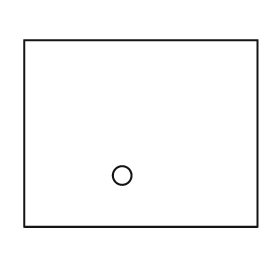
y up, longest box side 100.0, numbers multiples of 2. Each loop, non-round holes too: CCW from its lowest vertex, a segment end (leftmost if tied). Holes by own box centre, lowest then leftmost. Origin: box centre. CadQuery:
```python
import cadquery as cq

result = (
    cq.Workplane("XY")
    .moveTo(-50.0, -40.0)
    .lineTo(50.0, -40.0)
    .lineTo(50.0, 40.0)
    .lineTo(-50.0, 40.0)
    .close()
    .moveTo(-8.0, -18.0)
    .circle(4.0)
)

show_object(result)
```